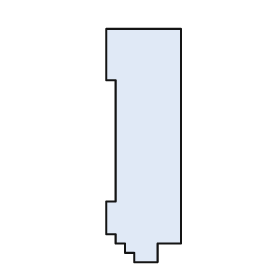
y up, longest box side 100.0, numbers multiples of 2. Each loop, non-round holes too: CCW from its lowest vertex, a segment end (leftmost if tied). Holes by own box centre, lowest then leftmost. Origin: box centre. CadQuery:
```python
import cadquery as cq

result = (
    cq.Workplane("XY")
    .moveTo(-4.0, -50.0)
    .lineTo(6.0, -50.0)
    .lineTo(6.0, -42.0)
    .lineTo(16.0, -42.0)
    .lineTo(16.0, 50.0)
    .lineTo(-16.0, 50.0)
    .lineTo(-16.0, 28.0)
    .lineTo(-12.0, 28.0)
    .lineTo(-12.0, -24.0)
    .lineTo(-16.0, -24.0)
    .lineTo(-16.0, -38.0)
    .lineTo(-12.0, -38.0)
    .lineTo(-12.0, -42.0)
    .lineTo(-8.0, -42.0)
    .lineTo(-8.0, -46.0)
    .lineTo(-4.0, -46.0)
    .close()
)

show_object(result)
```